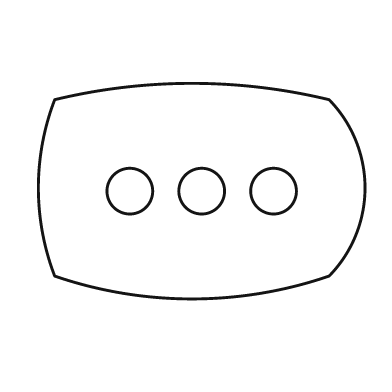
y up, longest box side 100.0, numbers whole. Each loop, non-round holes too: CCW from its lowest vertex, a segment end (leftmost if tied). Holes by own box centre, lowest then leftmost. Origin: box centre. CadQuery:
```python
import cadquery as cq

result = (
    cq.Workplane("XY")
    .moveTo(-45.0, -26.0)
    .threePointArc((-3.0, -33.0), (39.0, -26.0))
    .threePointArc((50.0, 1.0), (39.0, 28.0))
    .threePointArc((-3.0, 33.0), (-45.0, 28.0))
    .threePointArc((-50.0, 1.0), (-45.0, -26.0))
    .close()
    .moveTo(-22.0, 0.0)
    .circle(7.0)
    .moveTo(0.0, 0.0)
    .circle(7.0)
    .moveTo(22.0, 0.0)
    .circle(7.0)
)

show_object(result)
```